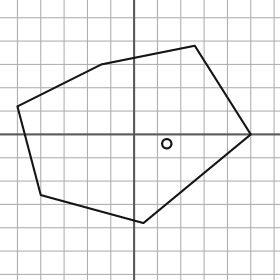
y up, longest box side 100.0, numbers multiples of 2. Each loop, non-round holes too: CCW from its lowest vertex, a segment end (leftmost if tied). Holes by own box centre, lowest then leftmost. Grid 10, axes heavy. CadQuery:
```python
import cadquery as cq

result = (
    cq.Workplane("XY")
    .moveTo(4.0, -38.0)
    .lineTo(50.0, 0.0)
    .lineTo(26.0, 38.0)
    .lineTo(-14.0, 30.0)
    .lineTo(-50.0, 12.0)
    .lineTo(-40.0, -26.0)
    .close()
    .moveTo(14.0, -4.0)
    .circle(2.0)
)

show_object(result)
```